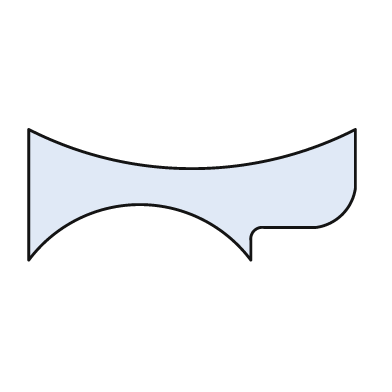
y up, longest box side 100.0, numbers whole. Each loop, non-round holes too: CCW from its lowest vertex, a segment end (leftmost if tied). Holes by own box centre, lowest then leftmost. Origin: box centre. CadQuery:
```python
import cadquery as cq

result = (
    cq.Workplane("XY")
    .moveTo(-50.0, -20.0)
    .threePointArc((-16.0, -3.0), (18.0, -20.0))
    .lineTo(18.0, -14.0)
    .threePointArc((19.0, -11.0), (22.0, -10.0))
    .lineTo(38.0, -10.0)
    .threePointArc((46.0, -6.0), (50.0, 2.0))
    .lineTo(50.0, 20.0)
    .threePointArc((0.0, 8.0), (-50.0, 20.0))
    .close()
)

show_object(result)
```